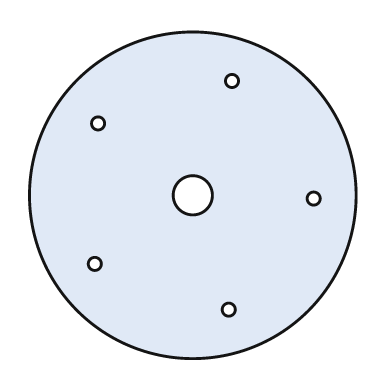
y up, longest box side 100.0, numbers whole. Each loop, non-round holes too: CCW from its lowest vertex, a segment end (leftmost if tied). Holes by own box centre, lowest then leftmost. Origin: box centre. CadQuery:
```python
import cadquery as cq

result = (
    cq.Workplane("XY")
    .moveTo(0.0, 0.0)
    .circle(50.0)
    .moveTo(11.0, -35.0)
    .circle(2.0)
    .moveTo(-30.0, -21.0)
    .circle(2.0)
    .moveTo(37.0, -1.0)
    .circle(2.0)
    .moveTo(0.0, 0.0)
    .circle(6.0)
    .moveTo(-29.0, 22.0)
    .circle(2.0)
    .moveTo(12.0, 35.0)
    .circle(2.0)
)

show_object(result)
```